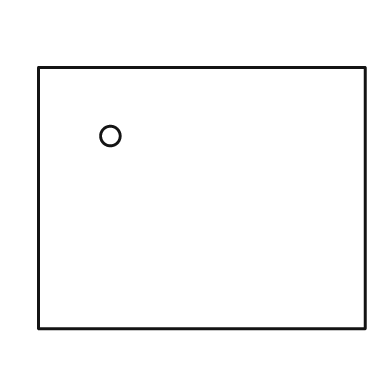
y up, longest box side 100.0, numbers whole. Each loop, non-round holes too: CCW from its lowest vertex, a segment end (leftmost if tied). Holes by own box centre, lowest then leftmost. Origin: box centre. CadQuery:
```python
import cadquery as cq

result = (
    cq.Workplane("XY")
    .moveTo(-50.0, -40.0)
    .lineTo(50.0, -40.0)
    .lineTo(50.0, 40.0)
    .lineTo(-50.0, 40.0)
    .close()
    .moveTo(-28.0, 19.0)
    .circle(3.0)
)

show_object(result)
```